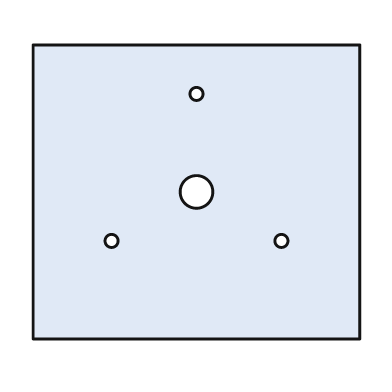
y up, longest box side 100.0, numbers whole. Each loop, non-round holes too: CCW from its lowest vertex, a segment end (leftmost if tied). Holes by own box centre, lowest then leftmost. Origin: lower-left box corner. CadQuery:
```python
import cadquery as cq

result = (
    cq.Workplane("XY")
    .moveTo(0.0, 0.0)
    .lineTo(100.0, 0.0)
    .lineTo(100.0, 90.0)
    .lineTo(0.0, 90.0)
    .close()
    .moveTo(24.0, 30.0)
    .circle(2.0)
    .moveTo(76.0, 30.0)
    .circle(2.0)
    .moveTo(50.0, 45.0)
    .circle(5.0)
    .moveTo(50.0, 75.0)
    .circle(2.0)
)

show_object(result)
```